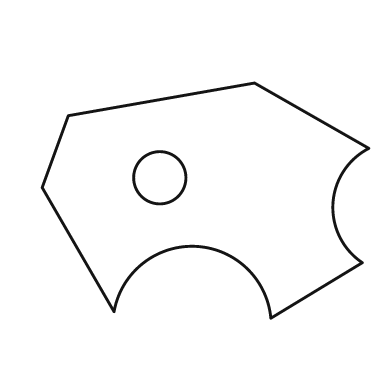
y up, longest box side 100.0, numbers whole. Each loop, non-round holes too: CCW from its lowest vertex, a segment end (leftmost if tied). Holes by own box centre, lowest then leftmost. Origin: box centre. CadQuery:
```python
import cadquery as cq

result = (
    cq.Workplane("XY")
    .moveTo(20.0, -36.0)
    .lineTo(48.0, -19.0)
    .threePointArc((39.0, -1.0), (50.0, 16.0))
    .lineTo(15.0, 36.0)
    .lineTo(-42.0, 26.0)
    .lineTo(-50.0, 4.0)
    .lineTo(-28.0, -34.0)
    .threePointArc((-3.0, -14.0), (20.0, -36.0))
    .close()
    .moveTo(-14.0, 7.0)
    .circle(8.0)
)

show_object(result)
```